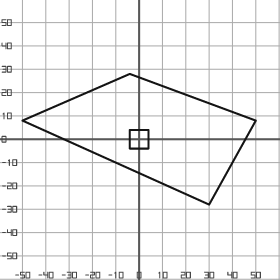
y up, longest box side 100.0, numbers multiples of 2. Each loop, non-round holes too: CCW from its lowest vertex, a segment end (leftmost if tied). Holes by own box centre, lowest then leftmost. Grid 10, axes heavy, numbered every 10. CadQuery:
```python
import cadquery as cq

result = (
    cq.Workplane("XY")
    .moveTo(30.0, -28.0)
    .lineTo(50.0, 8.0)
    .lineTo(-4.0, 28.0)
    .lineTo(-50.0, 8.0)
    .close()
    .moveTo(-4.0, -4.0)
    .lineTo(4.0, -4.0)
    .lineTo(4.0, 4.0)
    .lineTo(-4.0, 4.0)
    .close()
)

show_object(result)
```